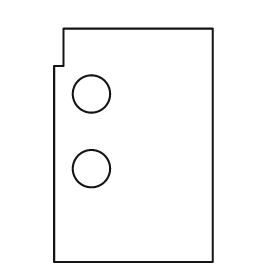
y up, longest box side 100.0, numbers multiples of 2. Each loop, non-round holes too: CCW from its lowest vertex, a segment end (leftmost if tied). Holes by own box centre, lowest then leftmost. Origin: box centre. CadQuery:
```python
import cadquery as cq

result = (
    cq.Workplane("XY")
    .moveTo(-34.0, -50.0)
    .lineTo(34.0, -50.0)
    .lineTo(34.0, 50.0)
    .lineTo(-30.0, 50.0)
    .lineTo(-30.0, 34.0)
    .lineTo(-34.0, 34.0)
    .close()
    .moveTo(-18.0, -10.0)
    .circle(8.0)
    .moveTo(-18.0, 22.0)
    .circle(8.0)
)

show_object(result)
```